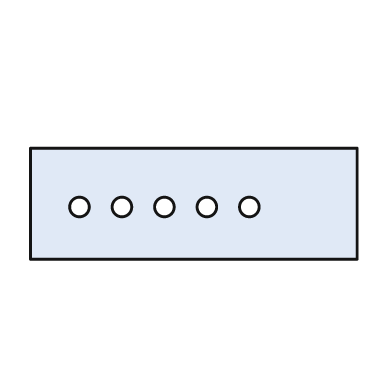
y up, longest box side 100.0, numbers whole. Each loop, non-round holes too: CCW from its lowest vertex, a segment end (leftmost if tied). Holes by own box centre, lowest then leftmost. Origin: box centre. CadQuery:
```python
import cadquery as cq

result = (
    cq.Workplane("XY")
    .moveTo(-50.0, -17.0)
    .lineTo(50.0, -17.0)
    .lineTo(50.0, 17.0)
    .lineTo(-50.0, 17.0)
    .close()
    .moveTo(-35.0, -1.0)
    .circle(3.0)
    .moveTo(-22.0, -1.0)
    .circle(3.0)
    .moveTo(-9.0, -1.0)
    .circle(3.0)
    .moveTo(4.0, -1.0)
    .circle(3.0)
    .moveTo(17.0, -1.0)
    .circle(3.0)
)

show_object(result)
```